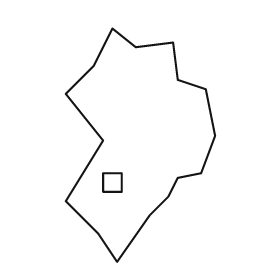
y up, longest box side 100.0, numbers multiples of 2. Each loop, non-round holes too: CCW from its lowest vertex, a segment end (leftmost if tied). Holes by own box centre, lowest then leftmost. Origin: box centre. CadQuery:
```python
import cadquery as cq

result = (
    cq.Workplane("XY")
    .moveTo(-10.0, -50.0)
    .lineTo(4.0, -30.0)
    .lineTo(12.0, -22.0)
    .lineTo(16.0, -14.0)
    .lineTo(26.0, -12.0)
    .lineTo(32.0, 4.0)
    .lineTo(28.0, 24.0)
    .lineTo(16.0, 28.0)
    .lineTo(14.0, 44.0)
    .lineTo(-2.0, 42.0)
    .lineTo(-12.0, 50.0)
    .lineTo(-20.0, 34.0)
    .lineTo(-32.0, 22.0)
    .lineTo(-16.0, 2.0)
    .lineTo(-32.0, -24.0)
    .lineTo(-18.0, -38.0)
    .close()
    .moveTo(-16.0, -20.0)
    .lineTo(-8.0, -20.0)
    .lineTo(-8.0, -12.0)
    .lineTo(-16.0, -12.0)
    .close()
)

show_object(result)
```